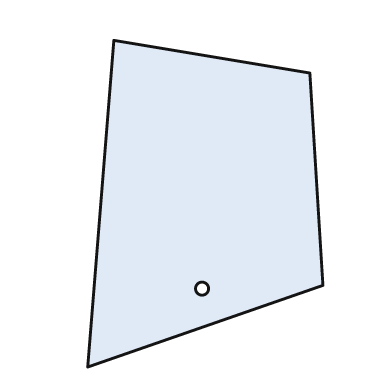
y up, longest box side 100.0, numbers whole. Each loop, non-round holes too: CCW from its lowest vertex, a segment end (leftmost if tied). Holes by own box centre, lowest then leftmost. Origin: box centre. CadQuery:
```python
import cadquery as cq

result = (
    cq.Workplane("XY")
    .moveTo(-36.0, -50.0)
    .lineTo(36.0, -25.0)
    .lineTo(32.0, 40.0)
    .lineTo(-28.0, 50.0)
    .close()
    .moveTo(-1.0, -26.0)
    .circle(2.0)
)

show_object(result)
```